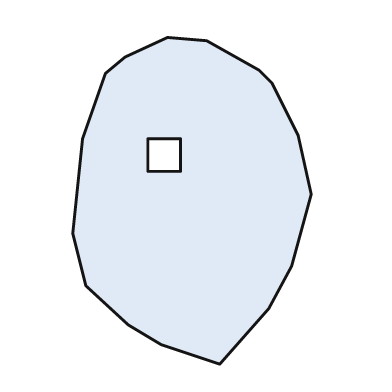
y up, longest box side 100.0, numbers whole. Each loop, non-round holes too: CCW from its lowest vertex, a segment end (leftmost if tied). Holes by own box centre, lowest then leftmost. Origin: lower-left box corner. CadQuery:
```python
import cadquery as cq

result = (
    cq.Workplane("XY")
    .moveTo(45.0, 0.0)
    .lineTo(60.0, 17.0)
    .lineTo(67.0, 30.0)
    .lineTo(73.0, 52.0)
    .lineTo(69.0, 70.0)
    .lineTo(61.0, 86.0)
    .lineTo(57.0, 90.0)
    .lineTo(41.0, 99.0)
    .lineTo(29.0, 100.0)
    .lineTo(16.0, 94.0)
    .lineTo(10.0, 89.0)
    .lineTo(3.0, 69.0)
    .lineTo(0.0, 40.0)
    .lineTo(4.0, 24.0)
    .lineTo(17.0, 12.0)
    .lineTo(27.0, 6.0)
    .close()
    .moveTo(23.0, 59.0)
    .lineTo(33.0, 59.0)
    .lineTo(33.0, 69.0)
    .lineTo(23.0, 69.0)
    .close()
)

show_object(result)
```